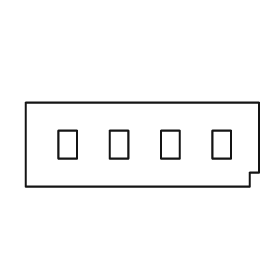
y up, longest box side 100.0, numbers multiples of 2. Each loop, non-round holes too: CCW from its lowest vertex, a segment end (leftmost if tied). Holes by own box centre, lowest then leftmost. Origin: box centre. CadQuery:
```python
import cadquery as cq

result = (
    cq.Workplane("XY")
    .moveTo(-50.0, -18.0)
    .lineTo(46.0, -18.0)
    .lineTo(46.0, -12.0)
    .lineTo(50.0, -12.0)
    .lineTo(50.0, 18.0)
    .lineTo(-50.0, 18.0)
    .close()
    .moveTo(-36.0, -6.0)
    .lineTo(-28.0, -6.0)
    .lineTo(-28.0, 6.0)
    .lineTo(-36.0, 6.0)
    .close()
    .moveTo(-14.0, -6.0)
    .lineTo(-6.0, -6.0)
    .lineTo(-6.0, 6.0)
    .lineTo(-14.0, 6.0)
    .close()
    .moveTo(8.0, -6.0)
    .lineTo(16.0, -6.0)
    .lineTo(16.0, 6.0)
    .lineTo(8.0, 6.0)
    .close()
    .moveTo(30.0, -6.0)
    .lineTo(38.0, -6.0)
    .lineTo(38.0, 6.0)
    .lineTo(30.0, 6.0)
    .close()
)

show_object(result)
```